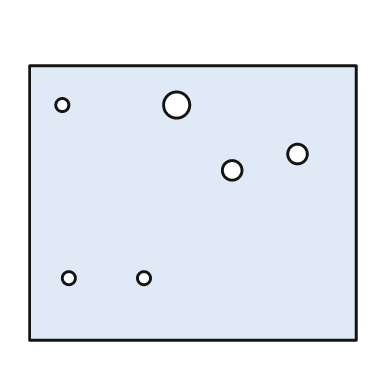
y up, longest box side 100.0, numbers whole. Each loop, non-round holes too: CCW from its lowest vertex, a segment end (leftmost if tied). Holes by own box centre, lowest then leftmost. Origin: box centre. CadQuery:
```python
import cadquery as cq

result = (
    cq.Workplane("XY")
    .moveTo(-50.0, -42.0)
    .lineTo(50.0, -42.0)
    .lineTo(50.0, 42.0)
    .lineTo(-50.0, 42.0)
    .close()
    .moveTo(-38.0, -23.0)
    .circle(2.0)
    .moveTo(-15.0, -23.0)
    .circle(2.0)
    .moveTo(12.0, 10.0)
    .circle(3.0)
    .moveTo(32.0, 15.0)
    .circle(3.0)
    .moveTo(-40.0, 30.0)
    .circle(2.0)
    .moveTo(-5.0, 30.0)
    .circle(4.0)
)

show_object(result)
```